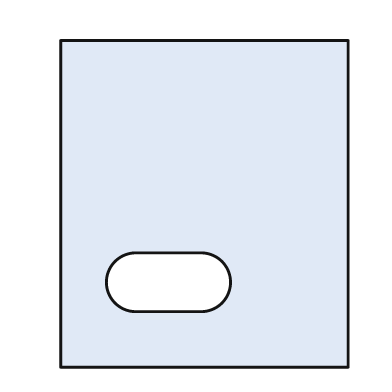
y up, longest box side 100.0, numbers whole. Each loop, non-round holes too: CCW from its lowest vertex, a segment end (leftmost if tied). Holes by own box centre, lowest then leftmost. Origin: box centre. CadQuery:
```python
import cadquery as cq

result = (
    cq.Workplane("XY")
    .moveTo(-44.0, -50.0)
    .lineTo(44.0, -50.0)
    .lineTo(44.0, 50.0)
    .lineTo(-44.0, 50.0)
    .close()
    .moveTo(-21.0, -33.0)
    .lineTo(-1.0, -33.0)
    .threePointArc((8.0, -24.0), (-1.0, -15.0))
    .lineTo(-21.0, -15.0)
    .threePointArc((-30.0, -24.0), (-21.0, -33.0))
    .close()
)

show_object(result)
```